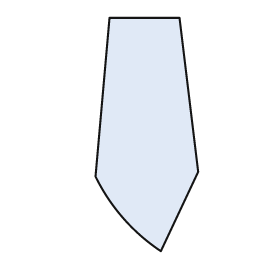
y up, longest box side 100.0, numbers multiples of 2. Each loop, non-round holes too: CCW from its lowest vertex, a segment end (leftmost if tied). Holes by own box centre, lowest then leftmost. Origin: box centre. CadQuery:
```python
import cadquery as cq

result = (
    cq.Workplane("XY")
    .moveTo(6.0, -50.0)
    .lineTo(22.0, -16.0)
    .lineTo(14.0, 50.0)
    .lineTo(-16.0, 50.0)
    .lineTo(-22.0, -18.0)
    .threePointArc((-10.0, -36.0), (6.0, -50.0))
    .close()
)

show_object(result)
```